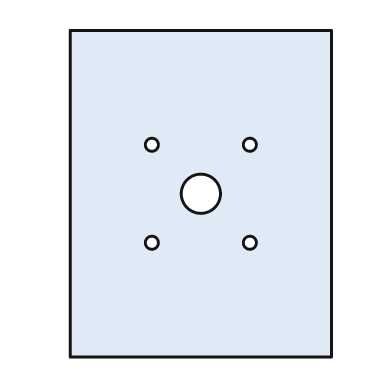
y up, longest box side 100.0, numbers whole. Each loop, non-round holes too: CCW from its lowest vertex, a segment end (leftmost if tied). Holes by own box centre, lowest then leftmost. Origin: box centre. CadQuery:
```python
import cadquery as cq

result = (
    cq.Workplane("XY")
    .moveTo(-40.0, -50.0)
    .lineTo(40.0, -50.0)
    .lineTo(40.0, 50.0)
    .lineTo(-40.0, 50.0)
    .close()
    .moveTo(-15.0, -15.0)
    .circle(2.0)
    .moveTo(15.0, -15.0)
    .circle(2.0)
    .moveTo(0.0, 0.0)
    .circle(6.0)
    .moveTo(-15.0, 15.0)
    .circle(2.0)
    .moveTo(15.0, 15.0)
    .circle(2.0)
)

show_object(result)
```